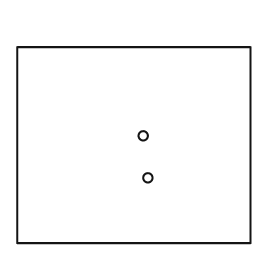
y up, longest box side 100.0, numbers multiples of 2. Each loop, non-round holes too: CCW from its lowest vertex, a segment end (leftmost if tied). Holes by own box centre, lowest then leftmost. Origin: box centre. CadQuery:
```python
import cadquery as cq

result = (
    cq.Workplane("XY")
    .moveTo(-50.0, -42.0)
    .lineTo(50.0, -42.0)
    .lineTo(50.0, 42.0)
    .lineTo(-50.0, 42.0)
    .close()
    .moveTo(6.0, -14.0)
    .circle(2.0)
    .moveTo(4.0, 4.0)
    .circle(2.0)
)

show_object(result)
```